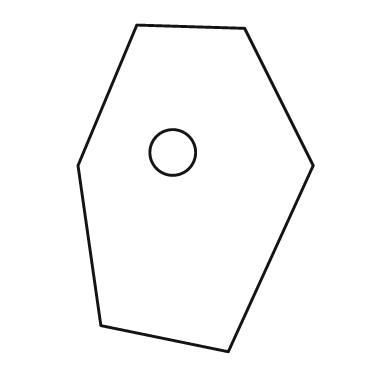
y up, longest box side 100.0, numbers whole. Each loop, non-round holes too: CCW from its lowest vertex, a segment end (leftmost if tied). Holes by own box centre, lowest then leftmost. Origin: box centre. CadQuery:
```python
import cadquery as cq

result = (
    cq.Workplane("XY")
    .moveTo(10.0, -50.0)
    .lineTo(36.0, 7.0)
    .lineTo(15.0, 49.0)
    .lineTo(-18.0, 50.0)
    .lineTo(-36.0, 7.0)
    .lineTo(-29.0, -42.0)
    .close()
    .moveTo(-7.0, 11.0)
    .circle(7.0)
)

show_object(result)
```